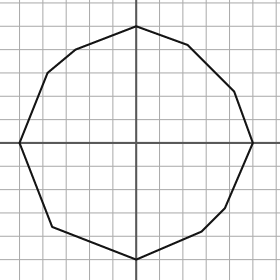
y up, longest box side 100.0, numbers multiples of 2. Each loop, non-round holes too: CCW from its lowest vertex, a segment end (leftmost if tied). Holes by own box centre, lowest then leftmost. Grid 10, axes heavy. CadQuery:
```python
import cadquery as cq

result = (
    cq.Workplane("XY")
    .moveTo(0.0, -50.0)
    .lineTo(28.0, -38.0)
    .lineTo(38.0, -28.0)
    .lineTo(50.0, 0.0)
    .lineTo(42.0, 22.0)
    .lineTo(22.0, 42.0)
    .lineTo(0.0, 50.0)
    .lineTo(-26.0, 40.0)
    .lineTo(-38.0, 30.0)
    .lineTo(-50.0, 0.0)
    .lineTo(-36.0, -36.0)
    .close()
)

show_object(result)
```